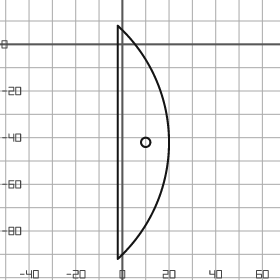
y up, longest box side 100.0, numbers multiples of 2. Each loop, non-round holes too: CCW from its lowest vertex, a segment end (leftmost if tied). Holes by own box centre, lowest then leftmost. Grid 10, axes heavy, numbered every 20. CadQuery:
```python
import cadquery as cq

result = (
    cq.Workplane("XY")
    .moveTo(-2.0, -92.0)
    .threePointArc((20.0, -42.0), (-2.0, 8.0))
    .close()
    .moveTo(10.0, -42.0)
    .circle(2.0)
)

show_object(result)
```